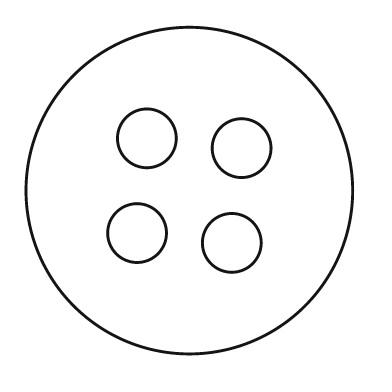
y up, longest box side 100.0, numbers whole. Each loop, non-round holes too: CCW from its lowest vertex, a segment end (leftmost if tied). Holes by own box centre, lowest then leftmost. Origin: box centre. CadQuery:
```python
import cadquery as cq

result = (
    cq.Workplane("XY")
    .moveTo(0.0, 0.0)
    .circle(50.0)
    .moveTo(13.0, -16.0)
    .circle(9.0)
    .moveTo(-16.0, -13.0)
    .circle(9.0)
    .moveTo(16.0, 13.0)
    .circle(9.0)
    .moveTo(-13.0, 16.0)
    .circle(9.0)
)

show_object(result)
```